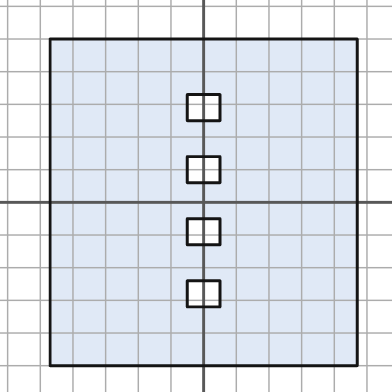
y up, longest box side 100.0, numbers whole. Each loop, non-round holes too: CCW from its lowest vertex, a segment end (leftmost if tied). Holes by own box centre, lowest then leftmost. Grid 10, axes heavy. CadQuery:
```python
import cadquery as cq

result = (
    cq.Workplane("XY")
    .moveTo(-47.0, -50.0)
    .lineTo(47.0, -50.0)
    .lineTo(47.0, 50.0)
    .lineTo(-47.0, 50.0)
    .close()
    .moveTo(-5.0, -32.0)
    .lineTo(5.0, -32.0)
    .lineTo(5.0, -24.0)
    .lineTo(-5.0, -24.0)
    .close()
    .moveTo(-5.0, -13.0)
    .lineTo(5.0, -13.0)
    .lineTo(5.0, -5.0)
    .lineTo(-5.0, -5.0)
    .close()
    .moveTo(-5.0, 6.0)
    .lineTo(5.0, 6.0)
    .lineTo(5.0, 14.0)
    .lineTo(-5.0, 14.0)
    .close()
    .moveTo(-5.0, 25.0)
    .lineTo(5.0, 25.0)
    .lineTo(5.0, 33.0)
    .lineTo(-5.0, 33.0)
    .close()
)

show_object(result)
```